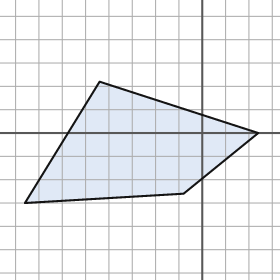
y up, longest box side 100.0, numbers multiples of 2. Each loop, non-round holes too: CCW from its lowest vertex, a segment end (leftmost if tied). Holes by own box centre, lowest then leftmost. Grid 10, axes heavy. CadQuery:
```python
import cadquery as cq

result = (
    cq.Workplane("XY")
    .moveTo(-76.0, -30.0)
    .lineTo(-8.0, -26.0)
    .lineTo(24.0, 0.0)
    .lineTo(-44.0, 22.0)
    .close()
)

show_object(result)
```